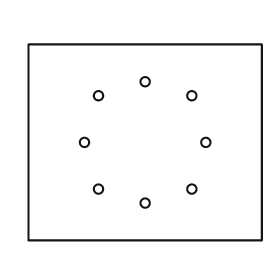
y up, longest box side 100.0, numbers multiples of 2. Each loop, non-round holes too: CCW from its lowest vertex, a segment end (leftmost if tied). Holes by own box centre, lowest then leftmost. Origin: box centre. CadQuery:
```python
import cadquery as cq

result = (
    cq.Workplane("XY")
    .moveTo(-50.0, -42.0)
    .lineTo(50.0, -42.0)
    .lineTo(50.0, 42.0)
    .lineTo(-50.0, 42.0)
    .close()
    .moveTo(0.0, -26.0)
    .circle(2.0)
    .moveTo(-20.0, -20.0)
    .circle(2.0)
    .moveTo(20.0, -20.0)
    .circle(2.0)
    .moveTo(-26.0, 0.0)
    .circle(2.0)
    .moveTo(26.0, 0.0)
    .circle(2.0)
    .moveTo(-20.0, 20.0)
    .circle(2.0)
    .moveTo(20.0, 20.0)
    .circle(2.0)
    .moveTo(0.0, 26.0)
    .circle(2.0)
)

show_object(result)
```